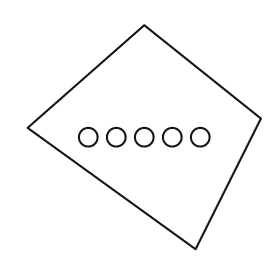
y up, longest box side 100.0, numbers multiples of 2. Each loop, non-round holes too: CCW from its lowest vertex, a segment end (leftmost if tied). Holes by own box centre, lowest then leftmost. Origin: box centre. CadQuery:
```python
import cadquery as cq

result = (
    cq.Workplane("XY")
    .moveTo(22.0, -48.0)
    .lineTo(50.0, 8.0)
    .lineTo(0.0, 48.0)
    .lineTo(-50.0, 4.0)
    .close()
    .moveTo(-24.0, 0.0)
    .circle(4.0)
    .moveTo(-12.0, 0.0)
    .circle(4.0)
    .moveTo(0.0, 0.0)
    .circle(4.0)
    .moveTo(12.0, 0.0)
    .circle(4.0)
    .moveTo(24.0, 0.0)
    .circle(4.0)
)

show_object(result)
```